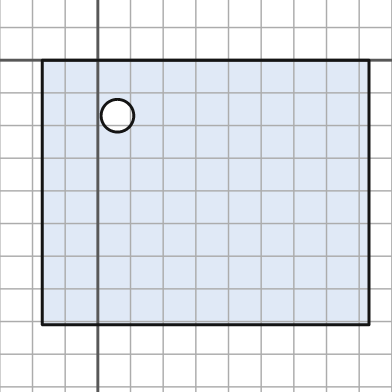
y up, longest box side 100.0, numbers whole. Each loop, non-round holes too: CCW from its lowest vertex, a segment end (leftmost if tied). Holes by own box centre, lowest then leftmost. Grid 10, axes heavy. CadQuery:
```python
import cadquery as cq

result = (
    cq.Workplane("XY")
    .moveTo(-17.0, -81.0)
    .lineTo(83.0, -81.0)
    .lineTo(83.0, 0.0)
    .lineTo(-17.0, 0.0)
    .close()
    .moveTo(6.0, -17.0)
    .circle(5.0)
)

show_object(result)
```